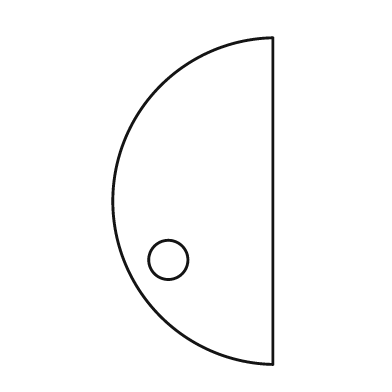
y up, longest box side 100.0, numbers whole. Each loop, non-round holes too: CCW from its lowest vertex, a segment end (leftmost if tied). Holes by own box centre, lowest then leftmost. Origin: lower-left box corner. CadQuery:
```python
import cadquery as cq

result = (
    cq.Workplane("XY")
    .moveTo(49.0, 0.0)
    .lineTo(49.0, 100.0)
    .threePointArc((0.0, 50.0), (49.0, 0.0))
    .close()
    .moveTo(17.0, 32.0)
    .circle(6.0)
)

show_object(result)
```